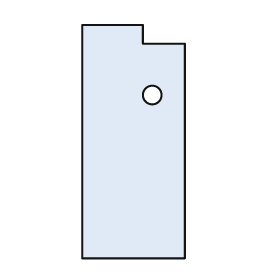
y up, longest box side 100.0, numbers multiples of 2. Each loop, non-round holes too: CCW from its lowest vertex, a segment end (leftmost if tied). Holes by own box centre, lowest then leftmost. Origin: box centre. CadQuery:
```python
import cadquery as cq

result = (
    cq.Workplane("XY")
    .moveTo(-22.0, -50.0)
    .lineTo(22.0, -50.0)
    .lineTo(22.0, 42.0)
    .lineTo(4.0, 42.0)
    .lineTo(4.0, 50.0)
    .lineTo(-22.0, 50.0)
    .close()
    .moveTo(8.0, 20.0)
    .circle(4.0)
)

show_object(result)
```